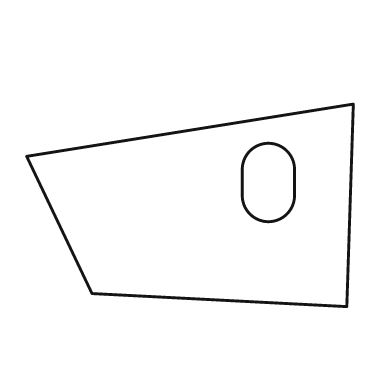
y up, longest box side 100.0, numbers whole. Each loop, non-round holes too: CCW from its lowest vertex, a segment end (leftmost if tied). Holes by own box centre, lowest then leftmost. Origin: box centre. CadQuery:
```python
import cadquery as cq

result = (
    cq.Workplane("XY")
    .moveTo(48.0, -31.0)
    .lineTo(50.0, 31.0)
    .lineTo(-50.0, 15.0)
    .lineTo(-30.0, -27.0)
    .close()
    .moveTo(16.0, 3.0)
    .threePointArc((24.0, -5.0), (32.0, 3.0))
    .lineTo(32.0, 11.0)
    .threePointArc((24.0, 19.0), (16.0, 11.0))
    .close()
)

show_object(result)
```